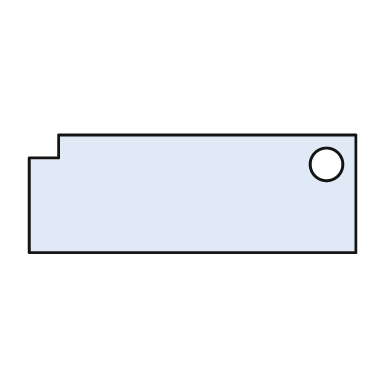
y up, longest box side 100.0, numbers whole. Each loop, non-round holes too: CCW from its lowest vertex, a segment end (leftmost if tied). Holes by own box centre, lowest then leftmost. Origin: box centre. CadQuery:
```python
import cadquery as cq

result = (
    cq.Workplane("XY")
    .moveTo(-50.0, -18.0)
    .lineTo(50.0, -18.0)
    .lineTo(50.0, 18.0)
    .lineTo(-41.0, 18.0)
    .lineTo(-41.0, 11.0)
    .lineTo(-50.0, 11.0)
    .close()
    .moveTo(41.0, 9.0)
    .circle(5.0)
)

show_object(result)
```